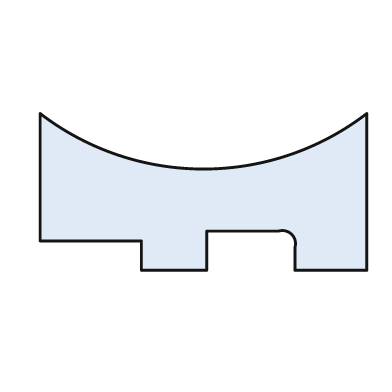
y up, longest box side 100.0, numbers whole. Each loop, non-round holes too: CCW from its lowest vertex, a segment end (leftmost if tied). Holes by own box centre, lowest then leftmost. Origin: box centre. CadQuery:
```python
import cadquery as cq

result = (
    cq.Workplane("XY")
    .moveTo(-19.0, -24.0)
    .lineTo(1.0, -24.0)
    .lineTo(1.0, -12.0)
    .lineTo(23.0, -12.0)
    .threePointArc((27.0, -13.0), (28.0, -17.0))
    .lineTo(28.0, -24.0)
    .lineTo(50.0, -24.0)
    .lineTo(50.0, 24.0)
    .threePointArc((0.0, 7.0), (-50.0, 24.0))
    .lineTo(-50.0, -15.0)
    .lineTo(-19.0, -15.0)
    .close()
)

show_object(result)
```